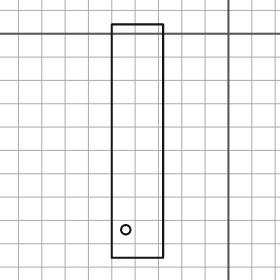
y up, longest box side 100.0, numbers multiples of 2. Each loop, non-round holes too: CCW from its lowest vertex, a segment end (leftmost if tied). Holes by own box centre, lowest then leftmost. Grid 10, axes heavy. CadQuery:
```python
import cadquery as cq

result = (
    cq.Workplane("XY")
    .moveTo(-50.0, -96.0)
    .lineTo(-28.0, -96.0)
    .lineTo(-28.0, 4.0)
    .lineTo(-50.0, 4.0)
    .close()
    .moveTo(-44.0, -84.0)
    .circle(2.0)
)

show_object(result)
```